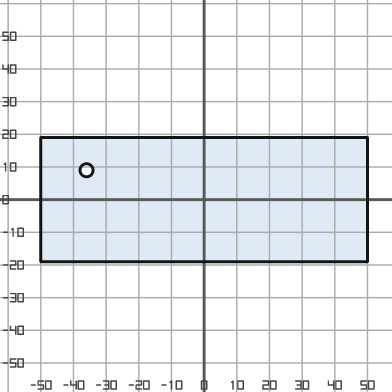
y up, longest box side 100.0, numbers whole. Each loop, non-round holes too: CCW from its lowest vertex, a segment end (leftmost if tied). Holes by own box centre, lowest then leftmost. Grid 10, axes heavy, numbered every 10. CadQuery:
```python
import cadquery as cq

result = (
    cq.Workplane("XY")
    .moveTo(-50.0, -19.0)
    .lineTo(50.0, -19.0)
    .lineTo(50.0, 19.0)
    .lineTo(-50.0, 19.0)
    .close()
    .moveTo(-36.0, 9.0)
    .circle(2.0)
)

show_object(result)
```